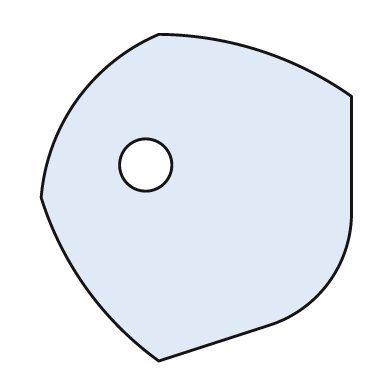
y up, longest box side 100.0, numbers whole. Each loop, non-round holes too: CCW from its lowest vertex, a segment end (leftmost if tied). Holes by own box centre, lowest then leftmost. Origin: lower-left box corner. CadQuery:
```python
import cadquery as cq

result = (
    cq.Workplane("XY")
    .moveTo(36.0, 0.0)
    .lineTo(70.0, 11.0)
    .threePointArc((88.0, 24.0), (95.0, 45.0))
    .lineTo(95.0, 81.0)
    .threePointArc((67.0, 95.0), (36.0, 100.0))
    .threePointArc((11.0, 80.0), (0.0, 50.0))
    .threePointArc((14.0, 22.0), (36.0, 0.0))
    .close()
    .moveTo(32.0, 60.0)
    .circle(8.0)
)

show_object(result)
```